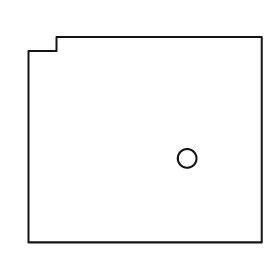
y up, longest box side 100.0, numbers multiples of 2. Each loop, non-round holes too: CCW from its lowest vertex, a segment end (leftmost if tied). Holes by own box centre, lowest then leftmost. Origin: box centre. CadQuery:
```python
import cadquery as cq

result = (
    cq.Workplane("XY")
    .moveTo(-50.0, -44.0)
    .lineTo(50.0, -44.0)
    .lineTo(50.0, 44.0)
    .lineTo(-38.0, 44.0)
    .lineTo(-38.0, 38.0)
    .lineTo(-50.0, 38.0)
    .close()
    .moveTo(18.0, -8.0)
    .circle(4.0)
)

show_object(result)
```